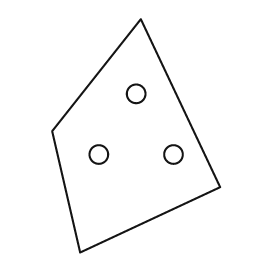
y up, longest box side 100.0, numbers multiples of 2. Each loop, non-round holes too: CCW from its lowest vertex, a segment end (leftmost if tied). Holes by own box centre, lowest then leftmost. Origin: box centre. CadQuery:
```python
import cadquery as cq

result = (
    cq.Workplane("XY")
    .moveTo(-24.0, -50.0)
    .lineTo(36.0, -22.0)
    .lineTo(2.0, 50.0)
    .lineTo(-36.0, 2.0)
    .close()
    .moveTo(-16.0, -8.0)
    .circle(4.0)
    .moveTo(16.0, -8.0)
    .circle(4.0)
    .moveTo(0.0, 18.0)
    .circle(4.0)
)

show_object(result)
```